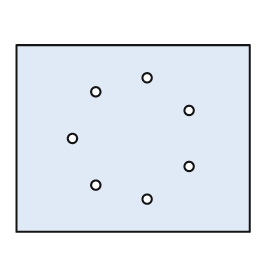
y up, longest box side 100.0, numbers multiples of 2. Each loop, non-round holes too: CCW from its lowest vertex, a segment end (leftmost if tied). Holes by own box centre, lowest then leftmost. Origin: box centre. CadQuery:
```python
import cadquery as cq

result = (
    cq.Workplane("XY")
    .moveTo(-50.0, -40.0)
    .lineTo(50.0, -40.0)
    .lineTo(50.0, 40.0)
    .lineTo(-50.0, 40.0)
    .close()
    .moveTo(6.0, -26.0)
    .circle(2.0)
    .moveTo(-16.0, -20.0)
    .circle(2.0)
    .moveTo(24.0, -12.0)
    .circle(2.0)
    .moveTo(-26.0, 0.0)
    .circle(2.0)
    .moveTo(24.0, 12.0)
    .circle(2.0)
    .moveTo(-16.0, 20.0)
    .circle(2.0)
    .moveTo(6.0, 26.0)
    .circle(2.0)
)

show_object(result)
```